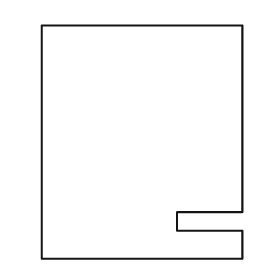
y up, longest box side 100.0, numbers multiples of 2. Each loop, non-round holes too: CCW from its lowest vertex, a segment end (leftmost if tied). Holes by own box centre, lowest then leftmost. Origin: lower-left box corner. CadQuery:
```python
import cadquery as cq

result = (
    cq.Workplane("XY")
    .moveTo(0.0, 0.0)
    .lineTo(86.0, 0.0)
    .lineTo(86.0, 12.0)
    .lineTo(58.0, 12.0)
    .lineTo(58.0, 20.0)
    .lineTo(86.0, 20.0)
    .lineTo(86.0, 100.0)
    .lineTo(0.0, 100.0)
    .close()
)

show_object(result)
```